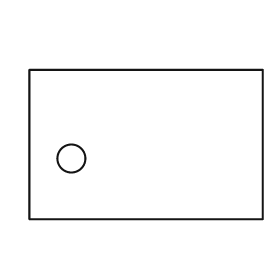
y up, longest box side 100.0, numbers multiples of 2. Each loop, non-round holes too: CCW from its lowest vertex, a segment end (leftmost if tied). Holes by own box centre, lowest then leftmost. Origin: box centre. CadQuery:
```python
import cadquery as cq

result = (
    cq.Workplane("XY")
    .moveTo(-50.0, -32.0)
    .lineTo(50.0, -32.0)
    .lineTo(50.0, 32.0)
    .lineTo(-50.0, 32.0)
    .close()
    .moveTo(-32.0, -6.0)
    .circle(6.0)
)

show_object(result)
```